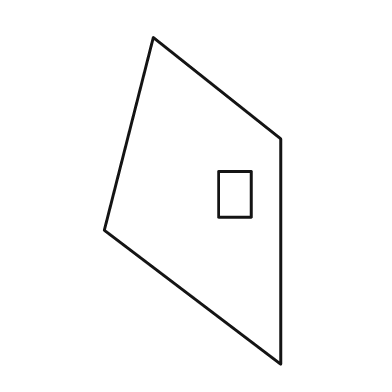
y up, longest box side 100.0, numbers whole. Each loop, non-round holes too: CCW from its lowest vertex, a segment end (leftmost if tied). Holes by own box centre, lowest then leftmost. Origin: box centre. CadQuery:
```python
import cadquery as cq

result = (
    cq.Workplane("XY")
    .moveTo(27.0, -50.0)
    .lineTo(27.0, 19.0)
    .lineTo(-12.0, 50.0)
    .lineTo(-27.0, -9.0)
    .close()
    .moveTo(8.0, -5.0)
    .lineTo(18.0, -5.0)
    .lineTo(18.0, 9.0)
    .lineTo(8.0, 9.0)
    .close()
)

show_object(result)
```